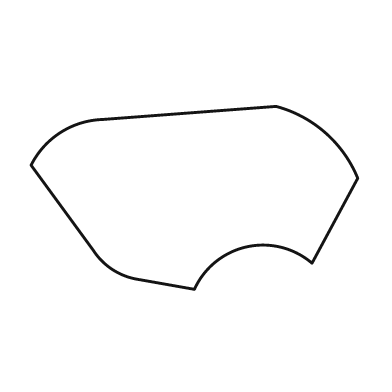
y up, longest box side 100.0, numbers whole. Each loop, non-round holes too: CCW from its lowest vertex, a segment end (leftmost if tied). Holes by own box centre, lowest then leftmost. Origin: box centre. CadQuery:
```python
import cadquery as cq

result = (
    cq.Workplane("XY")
    .moveTo(0.0, -28.0)
    .threePointArc((16.0, -15.0), (36.0, -20.0))
    .lineTo(50.0, 6.0)
    .threePointArc((40.0, 20.0), (25.0, 28.0))
    .lineTo(-28.0, 24.0)
    .threePointArc((-41.0, 20.0), (-50.0, 10.0))
    .lineTo(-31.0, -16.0)
    .threePointArc((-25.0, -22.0), (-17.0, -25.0))
    .close()
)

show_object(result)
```